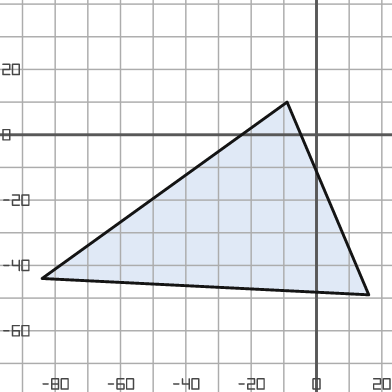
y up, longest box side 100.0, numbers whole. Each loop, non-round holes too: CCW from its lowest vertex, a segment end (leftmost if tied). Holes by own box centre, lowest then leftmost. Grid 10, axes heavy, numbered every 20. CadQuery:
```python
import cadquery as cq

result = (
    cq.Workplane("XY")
    .moveTo(16.0, -49.0)
    .lineTo(-9.0, 10.0)
    .lineTo(-84.0, -44.0)
    .close()
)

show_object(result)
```